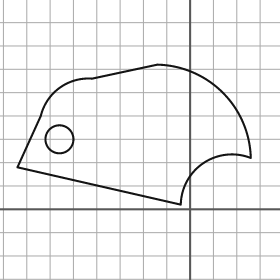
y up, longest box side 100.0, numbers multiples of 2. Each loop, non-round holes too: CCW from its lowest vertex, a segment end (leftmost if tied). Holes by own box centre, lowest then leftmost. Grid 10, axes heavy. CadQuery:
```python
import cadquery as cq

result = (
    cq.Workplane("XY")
    .moveTo(-4.0, 2.0)
    .threePointArc((6.0, 20.0), (26.0, 22.0))
    .threePointArc((14.0, 50.0), (-14.0, 62.0))
    .lineTo(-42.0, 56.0)
    .threePointArc((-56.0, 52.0), (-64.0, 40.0))
    .lineTo(-74.0, 18.0)
    .close()
    .moveTo(-56.0, 30.0)
    .circle(6.0)
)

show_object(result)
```